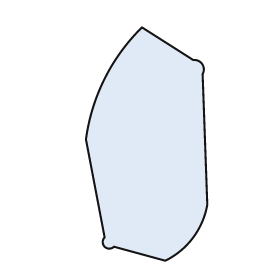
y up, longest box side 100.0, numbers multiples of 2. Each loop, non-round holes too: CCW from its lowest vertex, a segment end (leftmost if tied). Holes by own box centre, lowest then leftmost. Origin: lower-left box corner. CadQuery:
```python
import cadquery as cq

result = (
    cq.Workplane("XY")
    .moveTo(34.0, 0.0)
    .threePointArc((46.0, 10.0), (52.0, 24.0))
    .lineTo(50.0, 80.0)
    .threePointArc((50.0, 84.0), (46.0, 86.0))
    .lineTo(24.0, 100.0)
    .threePointArc((8.0, 78.0), (0.0, 52.0))
    .lineTo(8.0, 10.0)
    .threePointArc((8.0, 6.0), (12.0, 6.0))
    .close()
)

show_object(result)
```